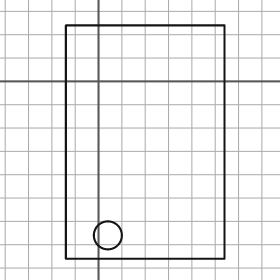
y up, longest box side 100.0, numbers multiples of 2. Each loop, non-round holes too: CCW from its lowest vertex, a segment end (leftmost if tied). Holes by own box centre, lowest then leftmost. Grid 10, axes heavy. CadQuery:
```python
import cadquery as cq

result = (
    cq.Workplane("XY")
    .moveTo(-14.0, -76.0)
    .lineTo(54.0, -76.0)
    .lineTo(54.0, 24.0)
    .lineTo(-14.0, 24.0)
    .close()
    .moveTo(4.0, -66.0)
    .circle(6.0)
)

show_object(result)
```